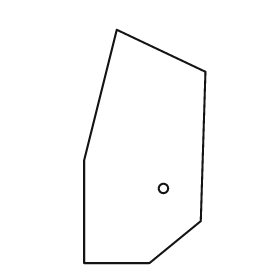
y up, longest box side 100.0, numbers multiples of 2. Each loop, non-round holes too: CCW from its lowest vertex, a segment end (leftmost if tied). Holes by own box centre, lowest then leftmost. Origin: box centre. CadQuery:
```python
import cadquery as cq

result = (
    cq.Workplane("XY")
    .moveTo(-26.0, -50.0)
    .lineTo(2.0, -50.0)
    .lineTo(24.0, -32.0)
    .lineTo(26.0, 32.0)
    .lineTo(-12.0, 50.0)
    .lineTo(-26.0, -6.0)
    .close()
    .moveTo(8.0, -18.0)
    .circle(2.0)
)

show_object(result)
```